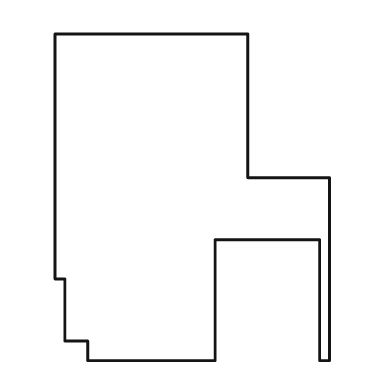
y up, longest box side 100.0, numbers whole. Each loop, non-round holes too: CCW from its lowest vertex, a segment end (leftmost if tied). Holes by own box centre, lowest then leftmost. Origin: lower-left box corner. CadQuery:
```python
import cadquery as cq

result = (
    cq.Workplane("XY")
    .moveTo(10.0, 0.0)
    .lineTo(49.0, 0.0)
    .lineTo(49.0, 37.0)
    .lineTo(81.0, 37.0)
    .lineTo(81.0, 0.0)
    .lineTo(84.0, 0.0)
    .lineTo(84.0, 56.0)
    .lineTo(59.0, 56.0)
    .lineTo(59.0, 100.0)
    .lineTo(0.0, 100.0)
    .lineTo(0.0, 25.0)
    .lineTo(3.0, 25.0)
    .lineTo(3.0, 6.0)
    .lineTo(10.0, 6.0)
    .close()
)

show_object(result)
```